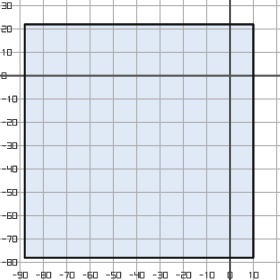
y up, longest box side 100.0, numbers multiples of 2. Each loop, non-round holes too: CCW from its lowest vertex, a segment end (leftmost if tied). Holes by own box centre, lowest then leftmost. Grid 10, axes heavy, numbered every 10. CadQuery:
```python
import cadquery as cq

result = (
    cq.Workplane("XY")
    .moveTo(-88.0, -78.0)
    .lineTo(10.0, -78.0)
    .lineTo(10.0, 22.0)
    .lineTo(-88.0, 22.0)
    .close()
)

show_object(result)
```